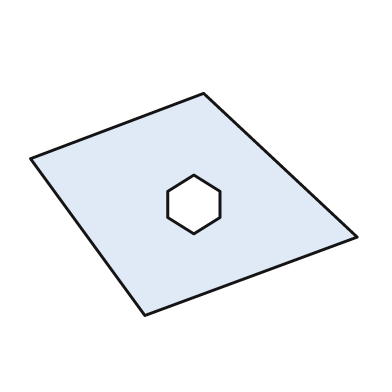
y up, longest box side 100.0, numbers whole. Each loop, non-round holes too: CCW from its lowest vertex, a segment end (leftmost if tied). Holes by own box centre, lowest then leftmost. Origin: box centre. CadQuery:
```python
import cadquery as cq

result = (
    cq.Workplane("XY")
    .moveTo(-15.0, -34.0)
    .lineTo(50.0, -10.0)
    .lineTo(3.0, 34.0)
    .lineTo(-50.0, 14.0)
    .close()
    .moveTo(0.0, -9.0)
    .lineTo(8.0, -4.0)
    .lineTo(8.0, 4.0)
    .lineTo(0.0, 9.0)
    .lineTo(-8.0, 4.0)
    .lineTo(-8.0, -4.0)
    .close()
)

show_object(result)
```